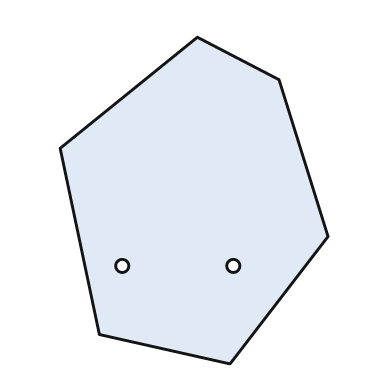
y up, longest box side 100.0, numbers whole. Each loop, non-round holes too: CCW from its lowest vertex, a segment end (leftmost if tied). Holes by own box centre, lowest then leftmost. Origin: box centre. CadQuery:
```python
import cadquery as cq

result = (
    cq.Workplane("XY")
    .moveTo(11.0, -50.0)
    .lineTo(41.0, -11.0)
    .lineTo(26.0, 37.0)
    .lineTo(1.0, 50.0)
    .lineTo(-41.0, 16.0)
    .lineTo(-29.0, -41.0)
    .close()
    .moveTo(-22.0, -20.0)
    .circle(2.0)
    .moveTo(12.0, -20.0)
    .circle(2.0)
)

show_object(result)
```